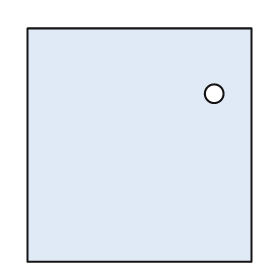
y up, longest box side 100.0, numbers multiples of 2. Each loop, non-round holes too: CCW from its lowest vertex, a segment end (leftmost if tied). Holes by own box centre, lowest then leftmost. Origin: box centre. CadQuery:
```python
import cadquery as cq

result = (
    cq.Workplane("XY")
    .moveTo(-48.0, -50.0)
    .lineTo(48.0, -50.0)
    .lineTo(48.0, 50.0)
    .lineTo(-48.0, 50.0)
    .close()
    .moveTo(32.0, 22.0)
    .circle(4.0)
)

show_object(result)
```